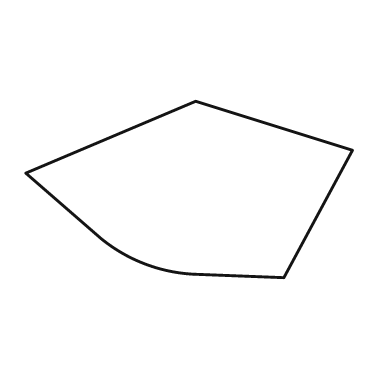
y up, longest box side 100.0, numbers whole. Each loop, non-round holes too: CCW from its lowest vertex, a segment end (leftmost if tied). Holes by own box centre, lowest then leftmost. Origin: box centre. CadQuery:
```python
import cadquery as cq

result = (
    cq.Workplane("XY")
    .moveTo(29.0, -27.0)
    .lineTo(50.0, 12.0)
    .lineTo(2.0, 27.0)
    .lineTo(-50.0, 5.0)
    .lineTo(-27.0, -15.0)
    .threePointArc((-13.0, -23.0), (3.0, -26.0))
    .close()
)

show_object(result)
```